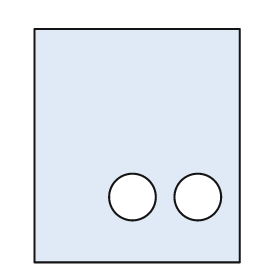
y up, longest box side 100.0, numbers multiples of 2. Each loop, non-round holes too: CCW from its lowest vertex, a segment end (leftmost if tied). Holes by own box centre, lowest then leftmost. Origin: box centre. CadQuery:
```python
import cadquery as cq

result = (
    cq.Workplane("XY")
    .moveTo(-44.0, -50.0)
    .lineTo(44.0, -50.0)
    .lineTo(44.0, 50.0)
    .lineTo(-44.0, 50.0)
    .close()
    .moveTo(-2.0, -22.0)
    .circle(10.0)
    .moveTo(26.0, -22.0)
    .circle(10.0)
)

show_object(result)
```